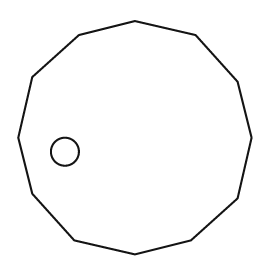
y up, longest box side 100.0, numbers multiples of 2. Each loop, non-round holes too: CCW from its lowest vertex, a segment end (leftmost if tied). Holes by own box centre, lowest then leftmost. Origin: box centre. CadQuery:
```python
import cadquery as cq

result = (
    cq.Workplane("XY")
    .moveTo(0.0, -50.0)
    .lineTo(24.0, -44.0)
    .lineTo(44.0, -26.0)
    .lineTo(50.0, 0.0)
    .lineTo(44.0, 24.0)
    .lineTo(26.0, 44.0)
    .lineTo(0.0, 50.0)
    .lineTo(-24.0, 44.0)
    .lineTo(-44.0, 26.0)
    .lineTo(-50.0, 0.0)
    .lineTo(-44.0, -24.0)
    .lineTo(-26.0, -44.0)
    .close()
    .moveTo(-30.0, -6.0)
    .circle(6.0)
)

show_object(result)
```